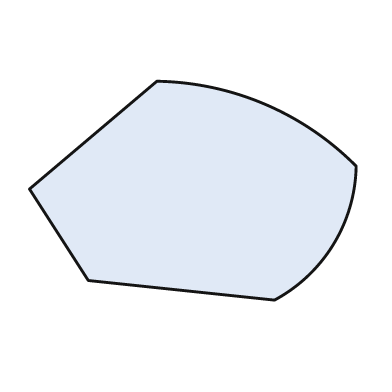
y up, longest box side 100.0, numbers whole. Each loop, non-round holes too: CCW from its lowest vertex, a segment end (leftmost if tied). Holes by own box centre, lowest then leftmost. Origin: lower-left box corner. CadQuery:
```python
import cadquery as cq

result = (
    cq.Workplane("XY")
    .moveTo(75.0, 0.0)
    .threePointArc((93.0, 17.0), (100.0, 41.0))
    .threePointArc((72.0, 60.0), (39.0, 67.0))
    .lineTo(0.0, 34.0)
    .lineTo(18.0, 6.0)
    .close()
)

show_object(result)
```